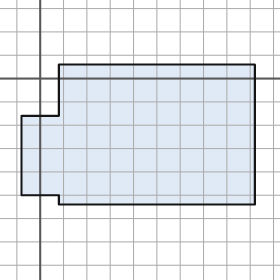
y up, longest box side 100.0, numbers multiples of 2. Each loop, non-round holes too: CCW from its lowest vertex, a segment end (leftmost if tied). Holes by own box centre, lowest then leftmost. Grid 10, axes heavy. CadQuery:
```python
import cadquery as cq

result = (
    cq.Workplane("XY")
    .moveTo(8.0, -54.0)
    .lineTo(92.0, -54.0)
    .lineTo(92.0, 6.0)
    .lineTo(8.0, 6.0)
    .lineTo(8.0, -16.0)
    .lineTo(-8.0, -16.0)
    .lineTo(-8.0, -50.0)
    .lineTo(8.0, -50.0)
    .close()
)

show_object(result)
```